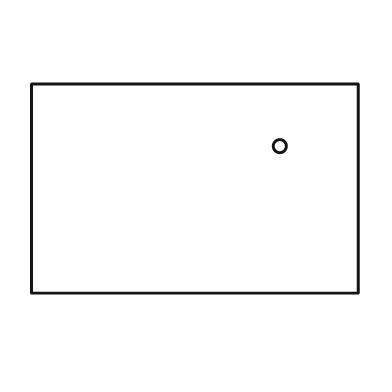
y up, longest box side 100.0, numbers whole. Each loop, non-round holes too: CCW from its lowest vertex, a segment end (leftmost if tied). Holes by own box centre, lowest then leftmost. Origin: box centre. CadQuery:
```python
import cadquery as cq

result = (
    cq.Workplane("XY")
    .moveTo(-50.0, -32.0)
    .lineTo(50.0, -32.0)
    .lineTo(50.0, 32.0)
    .lineTo(-50.0, 32.0)
    .close()
    .moveTo(26.0, 13.0)
    .circle(2.0)
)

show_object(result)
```